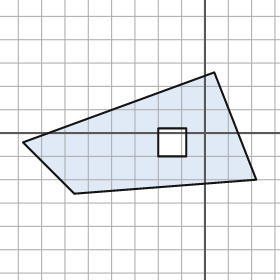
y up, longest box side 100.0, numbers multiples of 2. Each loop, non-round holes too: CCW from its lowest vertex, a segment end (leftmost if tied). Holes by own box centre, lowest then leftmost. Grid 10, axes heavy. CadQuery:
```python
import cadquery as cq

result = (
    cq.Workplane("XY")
    .moveTo(-56.0, -26.0)
    .lineTo(22.0, -20.0)
    .lineTo(4.0, 26.0)
    .lineTo(-78.0, -4.0)
    .close()
    .moveTo(-20.0, -10.0)
    .lineTo(-8.0, -10.0)
    .lineTo(-8.0, 2.0)
    .lineTo(-20.0, 2.0)
    .close()
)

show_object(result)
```